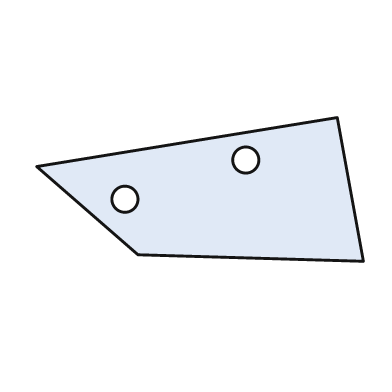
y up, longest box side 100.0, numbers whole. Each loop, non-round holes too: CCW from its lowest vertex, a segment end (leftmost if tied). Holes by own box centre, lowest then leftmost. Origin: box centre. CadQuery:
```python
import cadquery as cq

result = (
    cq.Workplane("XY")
    .moveTo(50.0, -22.0)
    .lineTo(42.0, 22.0)
    .lineTo(-50.0, 7.0)
    .lineTo(-19.0, -20.0)
    .close()
    .moveTo(-23.0, -3.0)
    .circle(4.0)
    .moveTo(14.0, 9.0)
    .circle(4.0)
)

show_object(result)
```